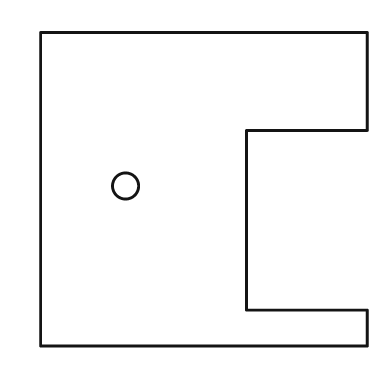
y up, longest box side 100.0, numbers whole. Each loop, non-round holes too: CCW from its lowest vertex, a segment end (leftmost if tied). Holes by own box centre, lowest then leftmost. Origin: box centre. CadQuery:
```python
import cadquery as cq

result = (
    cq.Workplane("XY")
    .moveTo(-50.0, -48.0)
    .lineTo(50.0, -48.0)
    .lineTo(50.0, -37.0)
    .lineTo(13.0, -37.0)
    .lineTo(13.0, 18.0)
    .lineTo(50.0, 18.0)
    .lineTo(50.0, 48.0)
    .lineTo(-50.0, 48.0)
    .close()
    .moveTo(-24.0, 1.0)
    .circle(4.0)
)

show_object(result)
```